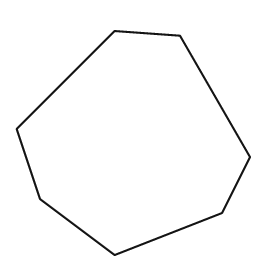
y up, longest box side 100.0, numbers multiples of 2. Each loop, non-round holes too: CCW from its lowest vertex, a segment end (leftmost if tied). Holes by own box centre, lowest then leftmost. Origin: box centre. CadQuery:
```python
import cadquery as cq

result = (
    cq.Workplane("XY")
    .moveTo(-8.0, -48.0)
    .lineTo(38.0, -30.0)
    .lineTo(50.0, -6.0)
    .lineTo(20.0, 46.0)
    .lineTo(-8.0, 48.0)
    .lineTo(-50.0, 6.0)
    .lineTo(-40.0, -24.0)
    .close()
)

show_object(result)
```